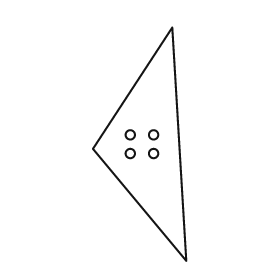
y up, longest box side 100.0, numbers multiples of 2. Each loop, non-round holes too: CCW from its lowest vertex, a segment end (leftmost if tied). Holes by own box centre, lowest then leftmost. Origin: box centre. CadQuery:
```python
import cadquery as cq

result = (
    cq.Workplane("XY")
    .moveTo(20.0, -50.0)
    .lineTo(14.0, 50.0)
    .lineTo(-20.0, -2.0)
    .close()
    .moveTo(-4.0, -4.0)
    .circle(2.0)
    .moveTo(6.0, -4.0)
    .circle(2.0)
    .moveTo(-4.0, 4.0)
    .circle(2.0)
    .moveTo(6.0, 4.0)
    .circle(2.0)
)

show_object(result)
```